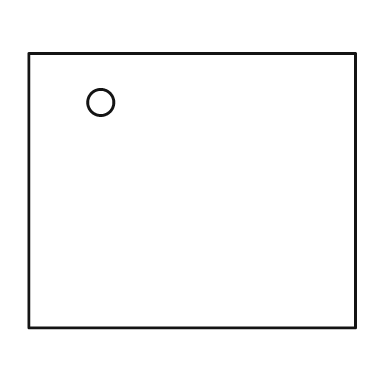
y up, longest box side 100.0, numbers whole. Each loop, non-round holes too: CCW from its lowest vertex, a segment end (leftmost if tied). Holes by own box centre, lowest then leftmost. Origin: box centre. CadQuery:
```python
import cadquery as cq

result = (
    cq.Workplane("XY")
    .moveTo(-50.0, -42.0)
    .lineTo(50.0, -42.0)
    .lineTo(50.0, 42.0)
    .lineTo(-50.0, 42.0)
    .close()
    .moveTo(-28.0, 27.0)
    .circle(4.0)
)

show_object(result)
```